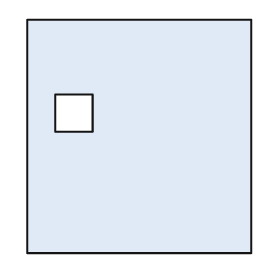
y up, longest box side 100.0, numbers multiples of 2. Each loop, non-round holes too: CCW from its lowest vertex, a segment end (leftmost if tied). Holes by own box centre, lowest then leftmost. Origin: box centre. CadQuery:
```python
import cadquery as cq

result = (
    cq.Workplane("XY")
    .moveTo(-48.0, -50.0)
    .lineTo(48.0, -50.0)
    .lineTo(48.0, 50.0)
    .lineTo(-48.0, 50.0)
    .close()
    .moveTo(-36.0, 2.0)
    .lineTo(-20.0, 2.0)
    .lineTo(-20.0, 18.0)
    .lineTo(-36.0, 18.0)
    .close()
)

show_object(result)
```